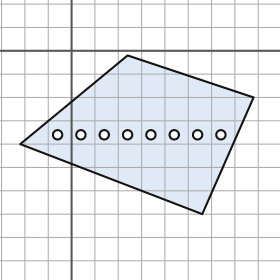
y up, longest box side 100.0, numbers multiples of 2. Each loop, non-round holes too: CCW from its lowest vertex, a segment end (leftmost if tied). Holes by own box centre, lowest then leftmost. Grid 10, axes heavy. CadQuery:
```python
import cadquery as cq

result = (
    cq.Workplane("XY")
    .moveTo(56.0, -70.0)
    .lineTo(78.0, -20.0)
    .lineTo(24.0, -2.0)
    .lineTo(-22.0, -40.0)
    .close()
    .moveTo(-6.0, -36.0)
    .circle(2.0)
    .moveTo(4.0, -36.0)
    .circle(2.0)
    .moveTo(14.0, -36.0)
    .circle(2.0)
    .moveTo(24.0, -36.0)
    .circle(2.0)
    .moveTo(34.0, -36.0)
    .circle(2.0)
    .moveTo(44.0, -36.0)
    .circle(2.0)
    .moveTo(54.0, -36.0)
    .circle(2.0)
    .moveTo(64.0, -36.0)
    .circle(2.0)
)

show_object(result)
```